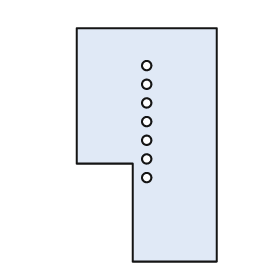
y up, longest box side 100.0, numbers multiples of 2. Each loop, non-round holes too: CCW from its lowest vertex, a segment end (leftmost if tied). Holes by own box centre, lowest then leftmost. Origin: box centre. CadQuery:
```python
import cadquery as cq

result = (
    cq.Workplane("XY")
    .moveTo(-6.0, -50.0)
    .lineTo(30.0, -50.0)
    .lineTo(30.0, 50.0)
    .lineTo(-30.0, 50.0)
    .lineTo(-30.0, -8.0)
    .lineTo(-6.0, -8.0)
    .close()
    .moveTo(0.0, -14.0)
    .circle(2.0)
    .moveTo(0.0, -6.0)
    .circle(2.0)
    .moveTo(0.0, 2.0)
    .circle(2.0)
    .moveTo(0.0, 10.0)
    .circle(2.0)
    .moveTo(0.0, 18.0)
    .circle(2.0)
    .moveTo(0.0, 26.0)
    .circle(2.0)
    .moveTo(0.0, 34.0)
    .circle(2.0)
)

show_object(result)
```